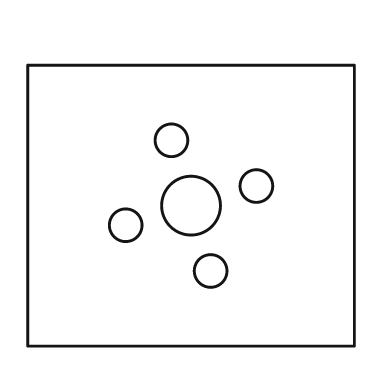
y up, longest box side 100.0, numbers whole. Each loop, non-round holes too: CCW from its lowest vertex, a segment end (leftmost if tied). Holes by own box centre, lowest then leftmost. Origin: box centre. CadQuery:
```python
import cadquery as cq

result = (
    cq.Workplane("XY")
    .moveTo(-50.0, -43.0)
    .lineTo(50.0, -43.0)
    .lineTo(50.0, 43.0)
    .lineTo(-50.0, 43.0)
    .close()
    .moveTo(6.0, -20.0)
    .circle(5.0)
    .moveTo(-20.0, -6.0)
    .circle(5.0)
    .moveTo(0.0, 0.0)
    .circle(9.0)
    .moveTo(20.0, 6.0)
    .circle(5.0)
    .moveTo(-6.0, 20.0)
    .circle(5.0)
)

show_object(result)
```